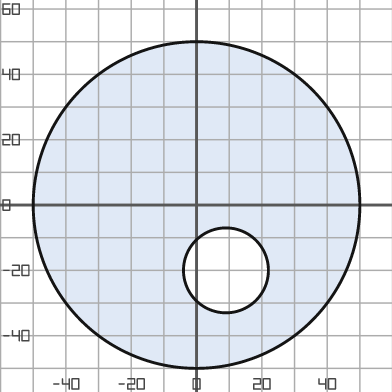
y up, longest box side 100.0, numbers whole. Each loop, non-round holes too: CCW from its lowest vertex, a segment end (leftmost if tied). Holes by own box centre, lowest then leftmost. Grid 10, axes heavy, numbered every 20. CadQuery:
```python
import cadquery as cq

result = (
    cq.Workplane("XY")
    .moveTo(0.0, 0.0)
    .circle(50.0)
    .moveTo(9.0, -20.0)
    .circle(13.0)
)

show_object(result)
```